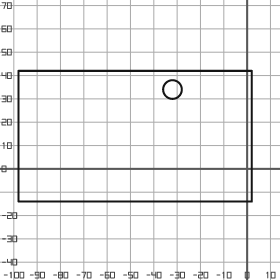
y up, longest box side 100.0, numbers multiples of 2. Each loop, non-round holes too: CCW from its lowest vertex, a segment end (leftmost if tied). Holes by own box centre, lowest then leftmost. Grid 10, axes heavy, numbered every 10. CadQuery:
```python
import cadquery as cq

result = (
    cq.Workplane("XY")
    .moveTo(-98.0, -14.0)
    .lineTo(2.0, -14.0)
    .lineTo(2.0, 42.0)
    .lineTo(-98.0, 42.0)
    .close()
    .moveTo(-32.0, 34.0)
    .circle(4.0)
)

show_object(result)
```